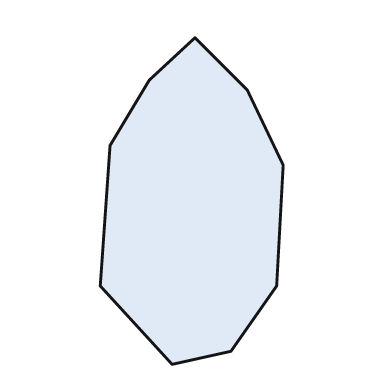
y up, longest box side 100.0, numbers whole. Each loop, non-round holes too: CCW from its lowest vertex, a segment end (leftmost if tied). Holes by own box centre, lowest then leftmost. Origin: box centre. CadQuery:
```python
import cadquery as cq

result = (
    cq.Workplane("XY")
    .moveTo(-6.0, -50.0)
    .lineTo(12.0, -46.0)
    .lineTo(26.0, -26.0)
    .lineTo(28.0, 11.0)
    .lineTo(17.0, 34.0)
    .lineTo(1.0, 50.0)
    .lineTo(-13.0, 37.0)
    .lineTo(-25.0, 17.0)
    .lineTo(-28.0, -26.0)
    .close()
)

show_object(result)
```